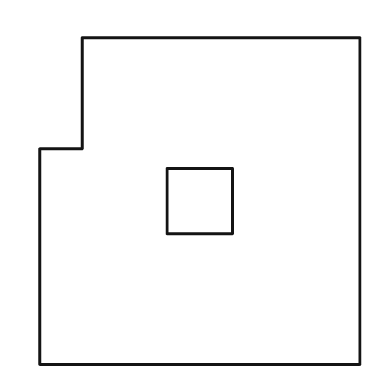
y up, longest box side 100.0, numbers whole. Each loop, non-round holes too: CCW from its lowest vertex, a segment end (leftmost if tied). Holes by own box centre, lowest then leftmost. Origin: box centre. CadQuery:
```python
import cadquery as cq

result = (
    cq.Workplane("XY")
    .moveTo(-49.0, -50.0)
    .lineTo(49.0, -50.0)
    .lineTo(49.0, 50.0)
    .lineTo(-36.0, 50.0)
    .lineTo(-36.0, 16.0)
    .lineTo(-49.0, 16.0)
    .close()
    .moveTo(-10.0, -10.0)
    .lineTo(10.0, -10.0)
    .lineTo(10.0, 10.0)
    .lineTo(-10.0, 10.0)
    .close()
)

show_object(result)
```